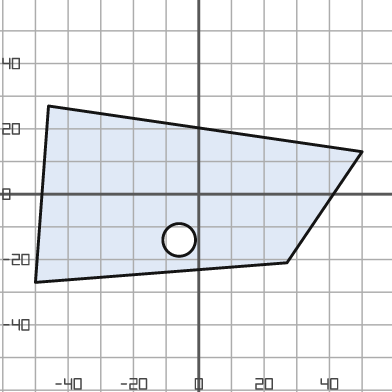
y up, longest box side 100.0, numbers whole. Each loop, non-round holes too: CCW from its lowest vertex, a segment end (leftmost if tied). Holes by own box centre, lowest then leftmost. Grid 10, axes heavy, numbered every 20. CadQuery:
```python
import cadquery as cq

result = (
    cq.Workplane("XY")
    .moveTo(-50.0, -27.0)
    .lineTo(27.0, -21.0)
    .lineTo(50.0, 13.0)
    .lineTo(-46.0, 27.0)
    .close()
    .moveTo(-6.0, -14.0)
    .circle(5.0)
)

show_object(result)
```